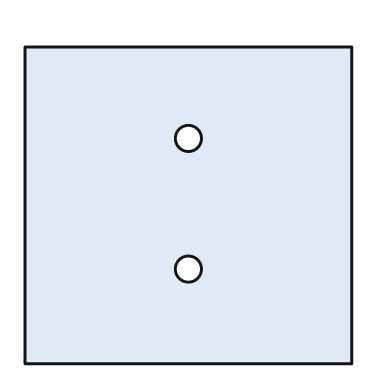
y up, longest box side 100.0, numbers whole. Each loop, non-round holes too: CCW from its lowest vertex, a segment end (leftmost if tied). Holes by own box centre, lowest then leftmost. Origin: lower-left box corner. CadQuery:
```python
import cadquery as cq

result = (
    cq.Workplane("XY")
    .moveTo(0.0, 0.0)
    .lineTo(100.0, 0.0)
    .lineTo(100.0, 97.0)
    .lineTo(0.0, 97.0)
    .close()
    .moveTo(50.0, 29.0)
    .circle(4.0)
    .moveTo(50.0, 69.0)
    .circle(4.0)
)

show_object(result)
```